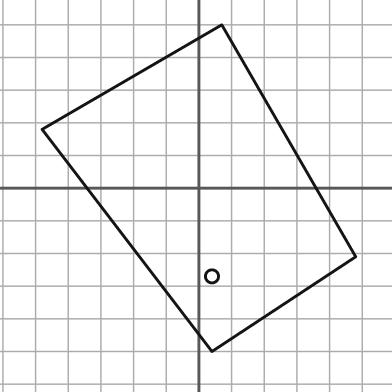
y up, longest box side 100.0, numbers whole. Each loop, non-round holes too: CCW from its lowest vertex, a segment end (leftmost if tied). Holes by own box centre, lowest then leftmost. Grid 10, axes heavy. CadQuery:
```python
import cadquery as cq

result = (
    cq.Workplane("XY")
    .moveTo(4.0, -50.0)
    .lineTo(48.0, -21.0)
    .lineTo(7.0, 50.0)
    .lineTo(-48.0, 18.0)
    .close()
    .moveTo(4.0, -27.0)
    .circle(2.0)
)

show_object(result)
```